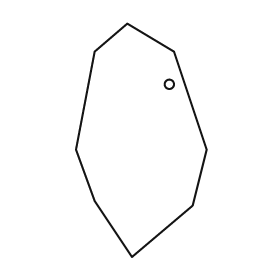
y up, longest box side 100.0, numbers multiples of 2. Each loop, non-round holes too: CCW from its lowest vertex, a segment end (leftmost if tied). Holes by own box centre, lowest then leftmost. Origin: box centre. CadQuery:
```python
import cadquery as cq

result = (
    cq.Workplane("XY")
    .moveTo(-4.0, -50.0)
    .lineTo(22.0, -28.0)
    .lineTo(28.0, -4.0)
    .lineTo(14.0, 38.0)
    .lineTo(-6.0, 50.0)
    .lineTo(-20.0, 38.0)
    .lineTo(-28.0, -4.0)
    .lineTo(-20.0, -26.0)
    .close()
    .moveTo(12.0, 24.0)
    .circle(2.0)
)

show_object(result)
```